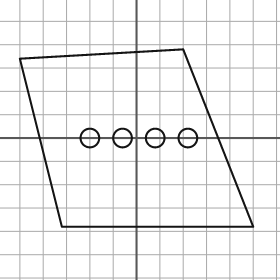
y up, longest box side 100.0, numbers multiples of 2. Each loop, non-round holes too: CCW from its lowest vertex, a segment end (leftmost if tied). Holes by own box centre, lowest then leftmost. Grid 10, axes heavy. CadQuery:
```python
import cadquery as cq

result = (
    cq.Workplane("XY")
    .moveTo(-32.0, -38.0)
    .lineTo(50.0, -38.0)
    .lineTo(20.0, 38.0)
    .lineTo(-50.0, 34.0)
    .close()
    .moveTo(-20.0, 0.0)
    .circle(4.0)
    .moveTo(-6.0, 0.0)
    .circle(4.0)
    .moveTo(8.0, 0.0)
    .circle(4.0)
    .moveTo(22.0, 0.0)
    .circle(4.0)
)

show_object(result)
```